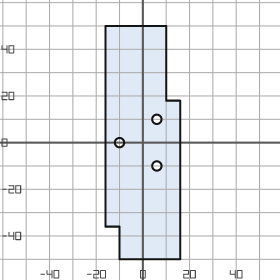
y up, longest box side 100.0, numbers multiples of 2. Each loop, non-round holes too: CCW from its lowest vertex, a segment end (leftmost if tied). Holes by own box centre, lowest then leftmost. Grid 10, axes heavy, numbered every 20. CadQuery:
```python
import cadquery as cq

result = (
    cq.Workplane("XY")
    .moveTo(-10.0, -50.0)
    .lineTo(16.0, -50.0)
    .lineTo(16.0, 18.0)
    .lineTo(10.0, 18.0)
    .lineTo(10.0, 50.0)
    .lineTo(-16.0, 50.0)
    .lineTo(-16.0, -36.0)
    .lineTo(-10.0, -36.0)
    .close()
    .moveTo(6.0, -10.0)
    .circle(2.0)
    .moveTo(-10.0, 0.0)
    .circle(2.0)
    .moveTo(6.0, 10.0)
    .circle(2.0)
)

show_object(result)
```